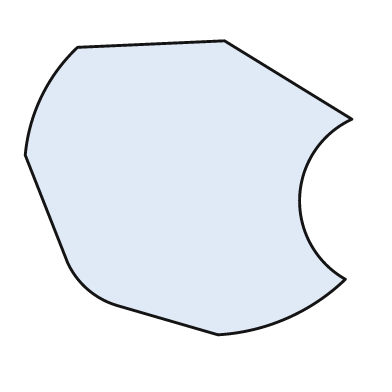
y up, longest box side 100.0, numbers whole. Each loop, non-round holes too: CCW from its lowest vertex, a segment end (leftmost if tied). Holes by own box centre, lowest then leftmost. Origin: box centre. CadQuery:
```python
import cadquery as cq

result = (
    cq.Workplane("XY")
    .moveTo(9.0, -45.0)
    .threePointArc((30.0, -40.0), (48.0, -28.0))
    .threePointArc((34.0, -3.0), (50.0, 21.0))
    .lineTo(11.0, 45.0)
    .lineTo(-34.0, 43.0)
    .threePointArc((-45.0, 28.0), (-50.0, 10.0))
    .lineTo(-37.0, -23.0)
    .threePointArc((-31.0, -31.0), (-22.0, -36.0))
    .close()
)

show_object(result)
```